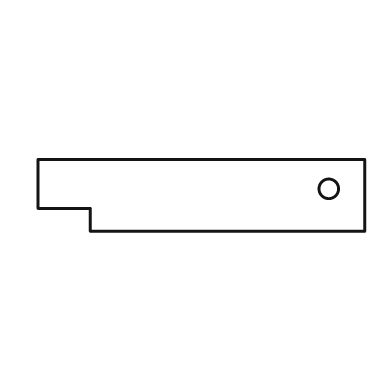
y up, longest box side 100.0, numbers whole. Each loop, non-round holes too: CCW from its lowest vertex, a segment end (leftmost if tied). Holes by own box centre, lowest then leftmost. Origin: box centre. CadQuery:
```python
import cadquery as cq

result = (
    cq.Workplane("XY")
    .moveTo(-34.0, -11.0)
    .lineTo(50.0, -11.0)
    .lineTo(50.0, 11.0)
    .lineTo(-50.0, 11.0)
    .lineTo(-50.0, -4.0)
    .lineTo(-34.0, -4.0)
    .close()
    .moveTo(39.0, 2.0)
    .circle(3.0)
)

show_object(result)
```